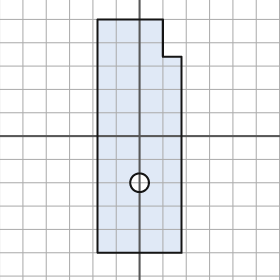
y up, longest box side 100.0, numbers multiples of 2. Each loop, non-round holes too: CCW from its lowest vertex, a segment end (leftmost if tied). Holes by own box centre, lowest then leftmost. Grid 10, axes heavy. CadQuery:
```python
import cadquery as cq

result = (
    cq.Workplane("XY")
    .moveTo(-18.0, -50.0)
    .lineTo(18.0, -50.0)
    .lineTo(18.0, 34.0)
    .lineTo(10.0, 34.0)
    .lineTo(10.0, 50.0)
    .lineTo(-18.0, 50.0)
    .close()
    .moveTo(0.0, -20.0)
    .circle(4.0)
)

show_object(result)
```